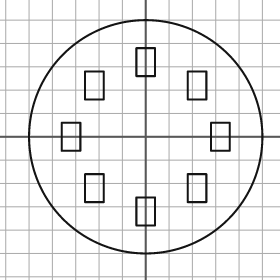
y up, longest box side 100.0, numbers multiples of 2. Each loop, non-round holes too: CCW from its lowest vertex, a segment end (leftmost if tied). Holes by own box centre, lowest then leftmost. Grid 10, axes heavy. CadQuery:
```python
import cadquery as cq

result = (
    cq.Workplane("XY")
    .moveTo(0.0, 0.0)
    .circle(50.0)
    .moveTo(-4.0, -38.0)
    .lineTo(4.0, -38.0)
    .lineTo(4.0, -26.0)
    .lineTo(-4.0, -26.0)
    .close()
    .moveTo(-26.0, -28.0)
    .lineTo(-18.0, -28.0)
    .lineTo(-18.0, -16.0)
    .lineTo(-26.0, -16.0)
    .close()
    .moveTo(18.0, -28.0)
    .lineTo(26.0, -28.0)
    .lineTo(26.0, -16.0)
    .lineTo(18.0, -16.0)
    .close()
    .moveTo(-36.0, -6.0)
    .lineTo(-28.0, -6.0)
    .lineTo(-28.0, 6.0)
    .lineTo(-36.0, 6.0)
    .close()
    .moveTo(28.0, -6.0)
    .lineTo(36.0, -6.0)
    .lineTo(36.0, 6.0)
    .lineTo(28.0, 6.0)
    .close()
    .moveTo(-26.0, 16.0)
    .lineTo(-18.0, 16.0)
    .lineTo(-18.0, 28.0)
    .lineTo(-26.0, 28.0)
    .close()
    .moveTo(18.0, 16.0)
    .lineTo(26.0, 16.0)
    .lineTo(26.0, 28.0)
    .lineTo(18.0, 28.0)
    .close()
    .moveTo(-4.0, 26.0)
    .lineTo(4.0, 26.0)
    .lineTo(4.0, 38.0)
    .lineTo(-4.0, 38.0)
    .close()
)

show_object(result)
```